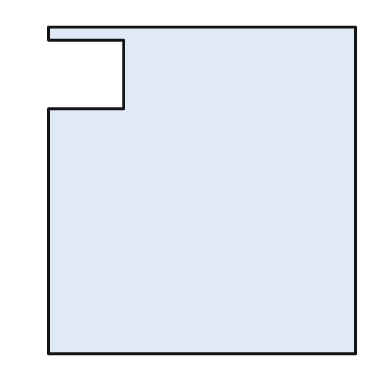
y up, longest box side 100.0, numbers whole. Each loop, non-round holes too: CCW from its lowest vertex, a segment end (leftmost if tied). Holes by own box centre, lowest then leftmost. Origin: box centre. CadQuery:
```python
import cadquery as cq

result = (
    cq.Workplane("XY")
    .moveTo(-47.0, -50.0)
    .lineTo(47.0, -50.0)
    .lineTo(47.0, 50.0)
    .lineTo(-47.0, 50.0)
    .lineTo(-47.0, 46.0)
    .lineTo(-24.0, 46.0)
    .lineTo(-24.0, 25.0)
    .lineTo(-47.0, 25.0)
    .close()
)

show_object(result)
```